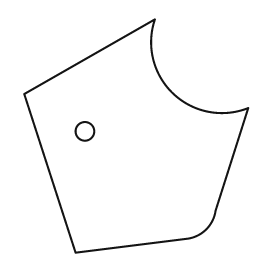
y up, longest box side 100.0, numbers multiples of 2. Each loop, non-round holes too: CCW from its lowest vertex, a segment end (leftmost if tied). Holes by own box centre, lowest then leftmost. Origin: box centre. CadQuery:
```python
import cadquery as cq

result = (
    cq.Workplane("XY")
    .moveTo(-26.0, -50.0)
    .lineTo(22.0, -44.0)
    .threePointArc((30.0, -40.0), (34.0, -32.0))
    .lineTo(48.0, 12.0)
    .threePointArc((16.0, 18.0), (8.0, 50.0))
    .lineTo(-48.0, 18.0)
    .close()
    .moveTo(-22.0, 2.0)
    .circle(4.0)
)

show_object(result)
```